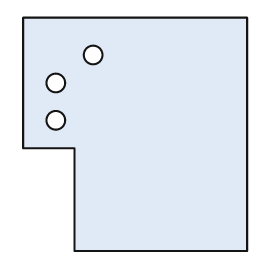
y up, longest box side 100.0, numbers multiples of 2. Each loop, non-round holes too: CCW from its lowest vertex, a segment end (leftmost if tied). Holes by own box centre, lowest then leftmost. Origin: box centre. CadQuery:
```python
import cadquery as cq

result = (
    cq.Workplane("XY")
    .moveTo(-26.0, -50.0)
    .lineTo(48.0, -50.0)
    .lineTo(48.0, 50.0)
    .lineTo(-48.0, 50.0)
    .lineTo(-48.0, -6.0)
    .lineTo(-26.0, -6.0)
    .close()
    .moveTo(-34.0, 6.0)
    .circle(4.0)
    .moveTo(-34.0, 22.0)
    .circle(4.0)
    .moveTo(-18.0, 34.0)
    .circle(4.0)
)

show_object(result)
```